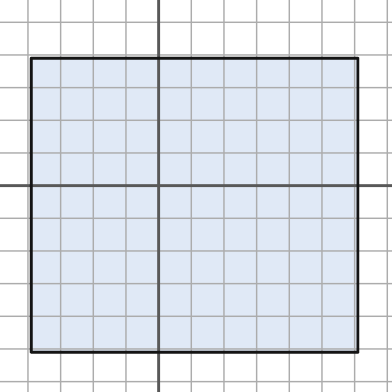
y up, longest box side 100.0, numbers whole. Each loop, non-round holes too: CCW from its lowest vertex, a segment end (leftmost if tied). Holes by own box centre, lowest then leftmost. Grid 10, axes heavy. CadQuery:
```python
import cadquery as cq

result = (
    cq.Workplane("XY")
    .moveTo(-39.0, -51.0)
    .lineTo(61.0, -51.0)
    .lineTo(61.0, 39.0)
    .lineTo(-39.0, 39.0)
    .close()
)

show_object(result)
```